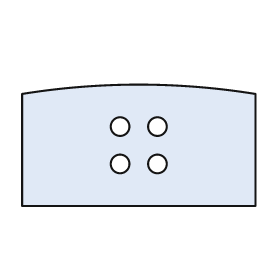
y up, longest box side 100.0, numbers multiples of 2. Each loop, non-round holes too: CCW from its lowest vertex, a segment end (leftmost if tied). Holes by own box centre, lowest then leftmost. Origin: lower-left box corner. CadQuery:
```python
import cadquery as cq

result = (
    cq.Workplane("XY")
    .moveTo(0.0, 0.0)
    .lineTo(100.0, 0.0)
    .lineTo(100.0, 48.0)
    .threePointArc((50.0, 52.0), (0.0, 48.0))
    .close()
    .moveTo(42.0, 18.0)
    .circle(4.0)
    .moveTo(58.0, 18.0)
    .circle(4.0)
    .moveTo(42.0, 34.0)
    .circle(4.0)
    .moveTo(58.0, 34.0)
    .circle(4.0)
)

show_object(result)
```